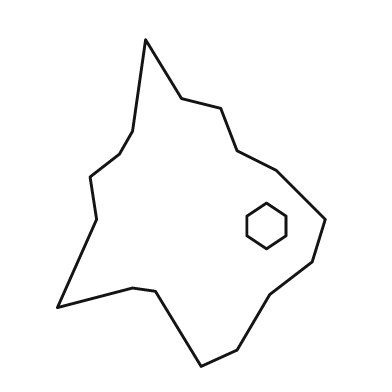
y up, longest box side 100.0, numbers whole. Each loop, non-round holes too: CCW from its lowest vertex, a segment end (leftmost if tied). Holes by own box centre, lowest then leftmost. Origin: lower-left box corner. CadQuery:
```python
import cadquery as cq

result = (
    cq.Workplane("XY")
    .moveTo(44.0, 0.0)
    .lineTo(55.0, 5.0)
    .lineTo(65.0, 22.0)
    .lineTo(78.0, 32.0)
    .lineTo(82.0, 45.0)
    .lineTo(67.0, 60.0)
    .lineTo(55.0, 66.0)
    .lineTo(50.0, 79.0)
    .lineTo(38.0, 82.0)
    .lineTo(27.0, 100.0)
    .lineTo(23.0, 72.0)
    .lineTo(19.0, 65.0)
    .lineTo(10.0, 58.0)
    .lineTo(12.0, 45.0)
    .lineTo(0.0, 18.0)
    .lineTo(23.0, 24.0)
    .lineTo(30.0, 23.0)
    .close()
    .moveTo(64.0, 36.0)
    .lineTo(70.0, 40.0)
    .lineTo(70.0, 46.0)
    .lineTo(64.0, 50.0)
    .lineTo(58.0, 46.0)
    .lineTo(58.0, 40.0)
    .close()
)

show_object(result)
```